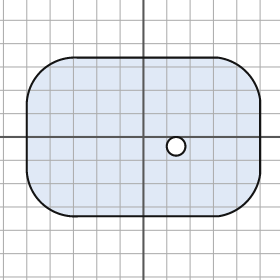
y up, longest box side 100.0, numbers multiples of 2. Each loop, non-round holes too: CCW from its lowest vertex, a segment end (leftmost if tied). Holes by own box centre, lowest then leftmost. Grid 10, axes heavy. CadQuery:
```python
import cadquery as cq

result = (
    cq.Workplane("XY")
    .moveTo(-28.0, -34.0)
    .lineTo(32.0, -34.0)
    .threePointArc((44.0, -28.0), (50.0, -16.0))
    .lineTo(50.0, 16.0)
    .threePointArc((44.0, 28.0), (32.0, 34.0))
    .lineTo(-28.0, 34.0)
    .threePointArc((-44.0, 28.0), (-50.0, 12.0))
    .lineTo(-50.0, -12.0)
    .threePointArc((-44.0, -28.0), (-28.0, -34.0))
    .close()
    .moveTo(14.0, -4.0)
    .circle(4.0)
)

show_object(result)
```